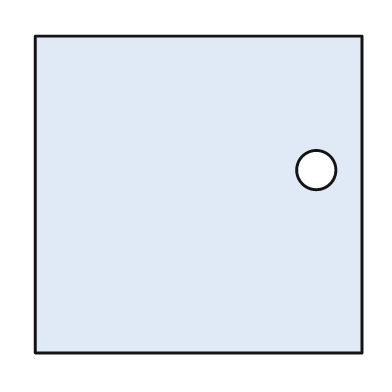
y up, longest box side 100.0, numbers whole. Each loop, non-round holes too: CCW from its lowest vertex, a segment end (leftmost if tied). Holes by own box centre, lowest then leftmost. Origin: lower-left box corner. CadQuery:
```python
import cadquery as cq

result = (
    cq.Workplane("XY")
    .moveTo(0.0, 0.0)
    .lineTo(100.0, 0.0)
    .lineTo(100.0, 97.0)
    .lineTo(0.0, 97.0)
    .close()
    .moveTo(86.0, 56.0)
    .circle(6.0)
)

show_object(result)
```